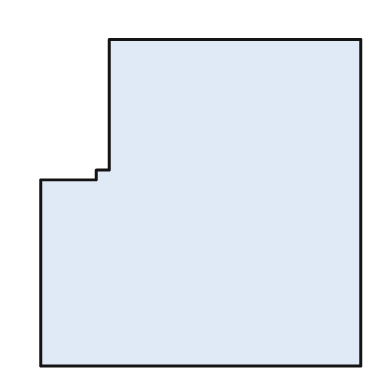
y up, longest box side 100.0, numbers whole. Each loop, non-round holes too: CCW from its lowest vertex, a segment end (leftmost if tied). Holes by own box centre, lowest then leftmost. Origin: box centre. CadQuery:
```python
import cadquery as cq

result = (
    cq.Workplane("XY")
    .moveTo(-49.0, -50.0)
    .lineTo(49.0, -50.0)
    .lineTo(49.0, 50.0)
    .lineTo(-28.0, 50.0)
    .lineTo(-28.0, 10.0)
    .lineTo(-32.0, 10.0)
    .lineTo(-32.0, 7.0)
    .lineTo(-49.0, 7.0)
    .close()
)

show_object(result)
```